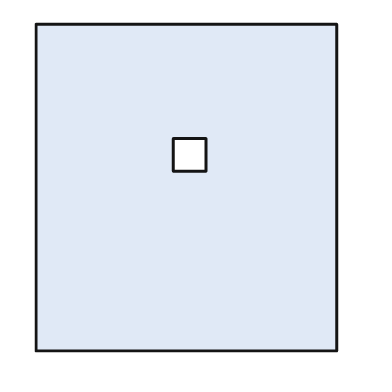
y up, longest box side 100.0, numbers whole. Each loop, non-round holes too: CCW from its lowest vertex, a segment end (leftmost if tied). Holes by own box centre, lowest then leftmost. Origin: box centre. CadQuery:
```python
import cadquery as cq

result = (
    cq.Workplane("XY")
    .moveTo(-46.0, -50.0)
    .lineTo(46.0, -50.0)
    .lineTo(46.0, 50.0)
    .lineTo(-46.0, 50.0)
    .close()
    .moveTo(-4.0, 5.0)
    .lineTo(6.0, 5.0)
    .lineTo(6.0, 15.0)
    .lineTo(-4.0, 15.0)
    .close()
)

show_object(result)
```